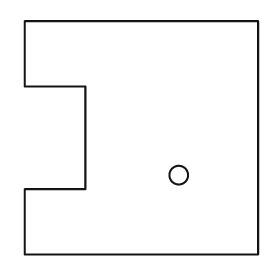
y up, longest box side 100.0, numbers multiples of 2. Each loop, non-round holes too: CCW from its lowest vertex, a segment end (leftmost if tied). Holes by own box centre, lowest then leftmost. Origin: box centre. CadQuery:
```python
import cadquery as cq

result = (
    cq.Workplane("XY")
    .moveTo(-50.0, -50.0)
    .lineTo(50.0, -50.0)
    .lineTo(50.0, 50.0)
    .lineTo(-50.0, 50.0)
    .lineTo(-50.0, 22.0)
    .lineTo(-24.0, 22.0)
    .lineTo(-24.0, -22.0)
    .lineTo(-50.0, -22.0)
    .close()
    .moveTo(16.0, -16.0)
    .circle(4.0)
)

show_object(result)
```